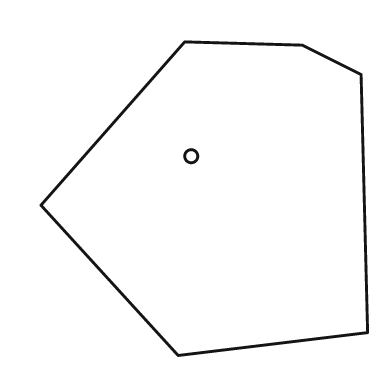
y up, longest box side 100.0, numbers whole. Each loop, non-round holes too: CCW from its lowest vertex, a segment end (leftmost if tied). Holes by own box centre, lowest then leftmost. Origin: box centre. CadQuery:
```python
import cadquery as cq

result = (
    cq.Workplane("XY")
    .moveTo(-8.0, -48.0)
    .lineTo(50.0, -41.0)
    .lineTo(48.0, 38.0)
    .lineTo(30.0, 47.0)
    .lineTo(-6.0, 48.0)
    .lineTo(-50.0, -2.0)
    .close()
    .moveTo(-4.0, 13.0)
    .circle(2.0)
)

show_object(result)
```